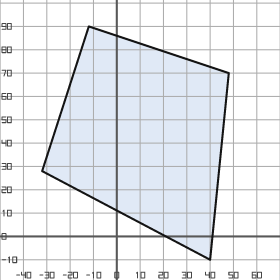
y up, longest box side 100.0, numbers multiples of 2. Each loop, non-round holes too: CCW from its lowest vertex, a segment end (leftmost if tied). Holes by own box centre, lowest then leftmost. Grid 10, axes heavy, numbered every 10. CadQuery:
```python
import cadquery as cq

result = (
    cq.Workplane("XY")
    .moveTo(40.0, -10.0)
    .lineTo(48.0, 70.0)
    .lineTo(-12.0, 90.0)
    .lineTo(-32.0, 28.0)
    .close()
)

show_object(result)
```